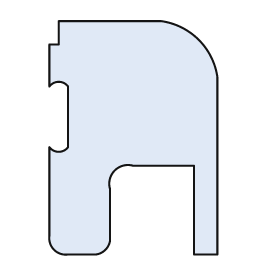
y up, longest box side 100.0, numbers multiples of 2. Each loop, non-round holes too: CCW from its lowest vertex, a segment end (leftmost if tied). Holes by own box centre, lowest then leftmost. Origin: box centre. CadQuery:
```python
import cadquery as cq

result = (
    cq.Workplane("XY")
    .moveTo(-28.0, -50.0)
    .lineTo(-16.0, -50.0)
    .threePointArc((-12.0, -48.0), (-10.0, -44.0))
    .lineTo(-10.0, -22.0)
    .threePointArc((-8.0, -14.0), (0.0, -12.0))
    .lineTo(26.0, -12.0)
    .lineTo(26.0, -50.0)
    .lineTo(36.0, -50.0)
    .lineTo(36.0, 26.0)
    .threePointArc((28.0, 42.0), (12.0, 50.0))
    .lineTo(-32.0, 50.0)
    .lineTo(-32.0, 40.0)
    .lineTo(-36.0, 40.0)
    .lineTo(-36.0, 22.0)
    .threePointArc((-32.0, 24.0), (-28.0, 22.0))
    .lineTo(-28.0, -4.0)
    .threePointArc((-32.0, -6.0), (-36.0, -4.0))
    .lineTo(-36.0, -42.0)
    .threePointArc((-34.0, -48.0), (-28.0, -50.0))
    .close()
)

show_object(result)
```